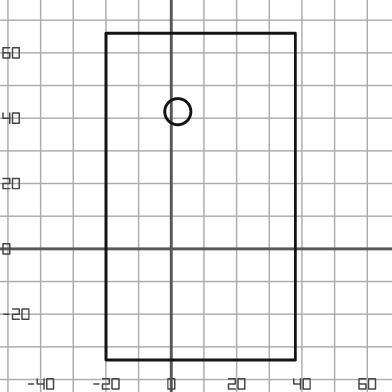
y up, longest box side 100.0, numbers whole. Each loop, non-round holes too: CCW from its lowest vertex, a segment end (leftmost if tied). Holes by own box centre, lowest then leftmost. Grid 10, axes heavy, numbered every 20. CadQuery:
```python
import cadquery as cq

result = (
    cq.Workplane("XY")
    .moveTo(-20.0, -34.0)
    .lineTo(38.0, -34.0)
    .lineTo(38.0, 66.0)
    .lineTo(-20.0, 66.0)
    .close()
    .moveTo(2.0, 42.0)
    .circle(4.0)
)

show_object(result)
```